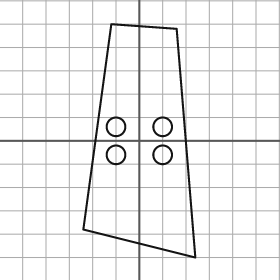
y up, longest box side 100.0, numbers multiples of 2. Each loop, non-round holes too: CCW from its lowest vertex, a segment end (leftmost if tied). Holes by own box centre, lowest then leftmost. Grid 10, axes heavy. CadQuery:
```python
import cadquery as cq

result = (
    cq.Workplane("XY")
    .moveTo(24.0, -50.0)
    .lineTo(16.0, 48.0)
    .lineTo(-12.0, 50.0)
    .lineTo(-24.0, -38.0)
    .close()
    .moveTo(-10.0, -6.0)
    .circle(4.0)
    .moveTo(10.0, -6.0)
    .circle(4.0)
    .moveTo(-10.0, 6.0)
    .circle(4.0)
    .moveTo(10.0, 6.0)
    .circle(4.0)
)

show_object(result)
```